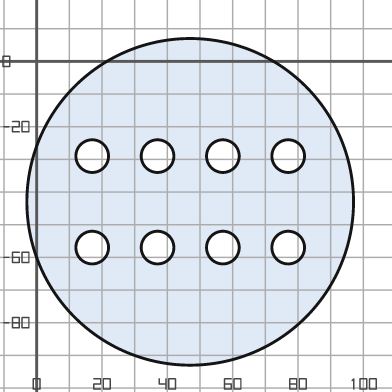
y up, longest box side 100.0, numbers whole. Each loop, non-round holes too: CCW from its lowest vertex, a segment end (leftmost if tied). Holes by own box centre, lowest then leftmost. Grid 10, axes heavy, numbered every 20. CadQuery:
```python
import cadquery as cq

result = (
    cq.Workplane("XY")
    .moveTo(47.0, -43.0)
    .circle(50.0)
    .moveTo(17.0, -57.0)
    .circle(5.0)
    .moveTo(37.0, -57.0)
    .circle(5.0)
    .moveTo(57.0, -57.0)
    .circle(5.0)
    .moveTo(77.0, -57.0)
    .circle(5.0)
    .moveTo(17.0, -29.0)
    .circle(5.0)
    .moveTo(37.0, -29.0)
    .circle(5.0)
    .moveTo(57.0, -29.0)
    .circle(5.0)
    .moveTo(77.0, -29.0)
    .circle(5.0)
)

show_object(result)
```